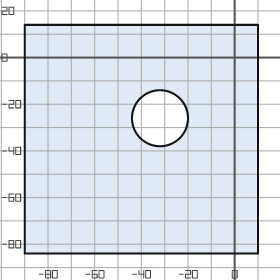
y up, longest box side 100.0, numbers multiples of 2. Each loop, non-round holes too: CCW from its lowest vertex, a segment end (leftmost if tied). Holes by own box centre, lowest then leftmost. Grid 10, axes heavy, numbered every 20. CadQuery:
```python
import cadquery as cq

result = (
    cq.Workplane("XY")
    .moveTo(-90.0, -84.0)
    .lineTo(10.0, -84.0)
    .lineTo(10.0, 14.0)
    .lineTo(-90.0, 14.0)
    .close()
    .moveTo(-32.0, -26.0)
    .circle(12.0)
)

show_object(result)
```